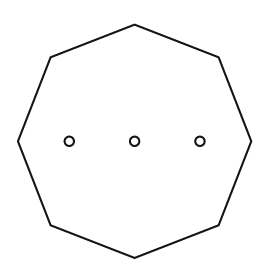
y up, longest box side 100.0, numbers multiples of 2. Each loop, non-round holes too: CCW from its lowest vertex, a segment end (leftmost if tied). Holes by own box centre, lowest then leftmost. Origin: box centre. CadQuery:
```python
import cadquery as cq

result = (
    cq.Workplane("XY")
    .moveTo(0.0, -50.0)
    .lineTo(36.0, -36.0)
    .lineTo(50.0, 0.0)
    .lineTo(36.0, 36.0)
    .lineTo(0.0, 50.0)
    .lineTo(-36.0, 36.0)
    .lineTo(-50.0, 0.0)
    .lineTo(-36.0, -36.0)
    .close()
    .moveTo(-28.0, 0.0)
    .circle(2.0)
    .moveTo(0.0, 0.0)
    .circle(2.0)
    .moveTo(28.0, 0.0)
    .circle(2.0)
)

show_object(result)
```